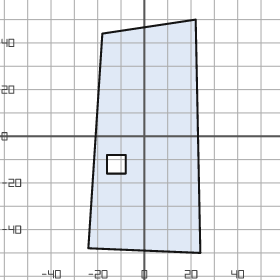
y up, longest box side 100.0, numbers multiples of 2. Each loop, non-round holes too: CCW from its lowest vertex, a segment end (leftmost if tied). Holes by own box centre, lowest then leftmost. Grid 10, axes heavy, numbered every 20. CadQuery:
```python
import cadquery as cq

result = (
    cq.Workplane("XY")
    .moveTo(24.0, -50.0)
    .lineTo(22.0, 50.0)
    .lineTo(-18.0, 44.0)
    .lineTo(-24.0, -48.0)
    .close()
    .moveTo(-16.0, -16.0)
    .lineTo(-8.0, -16.0)
    .lineTo(-8.0, -8.0)
    .lineTo(-16.0, -8.0)
    .close()
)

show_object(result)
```